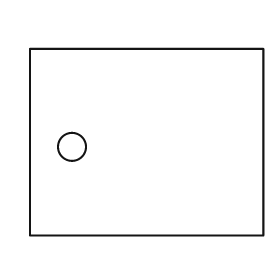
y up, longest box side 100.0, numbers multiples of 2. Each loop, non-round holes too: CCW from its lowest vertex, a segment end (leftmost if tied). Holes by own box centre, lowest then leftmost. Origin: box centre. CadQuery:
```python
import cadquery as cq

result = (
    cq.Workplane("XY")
    .moveTo(-50.0, -40.0)
    .lineTo(50.0, -40.0)
    .lineTo(50.0, 40.0)
    .lineTo(-50.0, 40.0)
    .close()
    .moveTo(-32.0, -2.0)
    .circle(6.0)
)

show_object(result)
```